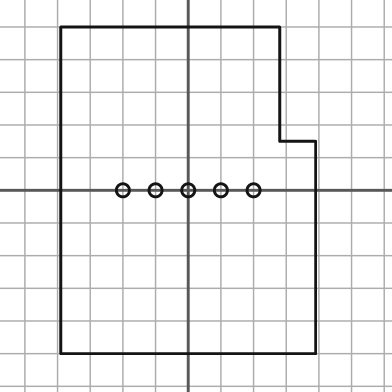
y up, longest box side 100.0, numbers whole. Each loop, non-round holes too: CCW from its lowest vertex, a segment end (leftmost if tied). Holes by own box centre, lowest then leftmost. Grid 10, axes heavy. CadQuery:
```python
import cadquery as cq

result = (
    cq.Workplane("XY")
    .moveTo(-39.0, -50.0)
    .lineTo(39.0, -50.0)
    .lineTo(39.0, 15.0)
    .lineTo(28.0, 15.0)
    .lineTo(28.0, 50.0)
    .lineTo(-39.0, 50.0)
    .close()
    .moveTo(-20.0, 0.0)
    .circle(2.0)
    .moveTo(-10.0, 0.0)
    .circle(2.0)
    .moveTo(0.0, 0.0)
    .circle(2.0)
    .moveTo(10.0, 0.0)
    .circle(2.0)
    .moveTo(20.0, 0.0)
    .circle(2.0)
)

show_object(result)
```